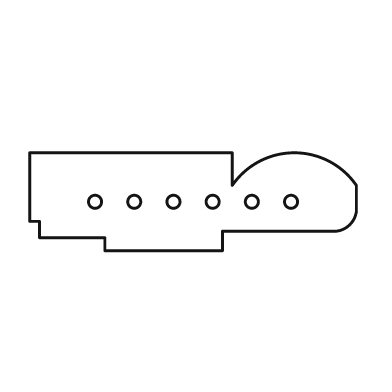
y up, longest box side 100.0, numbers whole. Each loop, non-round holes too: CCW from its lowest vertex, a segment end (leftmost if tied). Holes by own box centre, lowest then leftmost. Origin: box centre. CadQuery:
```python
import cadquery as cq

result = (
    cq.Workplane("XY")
    .moveTo(-27.0, -15.0)
    .lineTo(9.0, -15.0)
    .lineTo(9.0, -9.0)
    .lineTo(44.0, -9.0)
    .threePointArc((48.0, -7.0), (50.0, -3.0))
    .lineTo(50.0, 5.0)
    .threePointArc((31.0, 15.0), (12.0, 5.0))
    .lineTo(12.0, 15.0)
    .lineTo(-50.0, 15.0)
    .lineTo(-50.0, -6.0)
    .lineTo(-47.0, -6.0)
    .lineTo(-47.0, -11.0)
    .lineTo(-27.0, -11.0)
    .close()
    .moveTo(-30.0, 0.0)
    .circle(2.0)
    .moveTo(-18.0, 0.0)
    .circle(2.0)
    .moveTo(-6.0, 0.0)
    .circle(2.0)
    .moveTo(6.0, 0.0)
    .circle(2.0)
    .moveTo(18.0, 0.0)
    .circle(2.0)
    .moveTo(30.0, 0.0)
    .circle(2.0)
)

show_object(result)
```